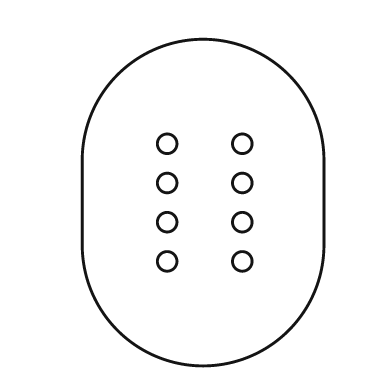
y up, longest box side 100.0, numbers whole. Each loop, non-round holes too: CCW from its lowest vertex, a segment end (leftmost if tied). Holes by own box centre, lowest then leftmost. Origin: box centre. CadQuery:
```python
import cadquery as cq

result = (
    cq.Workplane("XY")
    .moveTo(-37.0, -13.0)
    .threePointArc((0.0, -50.0), (37.0, -13.0))
    .lineTo(37.0, 13.0)
    .threePointArc((0.0, 50.0), (-37.0, 13.0))
    .close()
    .moveTo(-11.0, -18.0)
    .circle(3.0)
    .moveTo(12.0, -18.0)
    .circle(3.0)
    .moveTo(-11.0, -6.0)
    .circle(3.0)
    .moveTo(12.0, -6.0)
    .circle(3.0)
    .moveTo(-11.0, 6.0)
    .circle(3.0)
    .moveTo(12.0, 6.0)
    .circle(3.0)
    .moveTo(-11.0, 18.0)
    .circle(3.0)
    .moveTo(12.0, 18.0)
    .circle(3.0)
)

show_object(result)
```